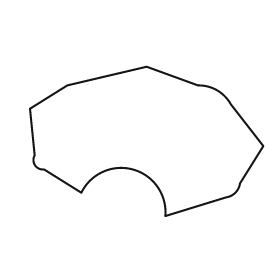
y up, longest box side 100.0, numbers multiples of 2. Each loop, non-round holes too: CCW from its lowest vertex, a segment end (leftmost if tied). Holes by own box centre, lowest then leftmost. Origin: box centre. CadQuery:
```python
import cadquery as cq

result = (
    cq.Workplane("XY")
    .moveTo(8.0, -32.0)
    .lineTo(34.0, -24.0)
    .threePointArc((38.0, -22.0), (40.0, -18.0))
    .lineTo(50.0, -2.0)
    .lineTo(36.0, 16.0)
    .threePointArc((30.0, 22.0), (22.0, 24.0))
    .lineTo(0.0, 32.0)
    .lineTo(-34.0, 24.0)
    .lineTo(-50.0, 14.0)
    .lineTo(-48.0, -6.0)
    .threePointArc((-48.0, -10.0), (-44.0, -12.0))
    .lineTo(-28.0, -22.0)
    .threePointArc((-6.0, -12.0), (8.0, -32.0))
    .close()
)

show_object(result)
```